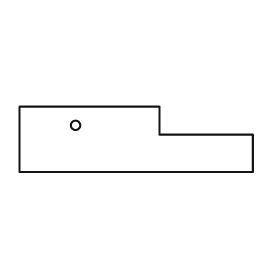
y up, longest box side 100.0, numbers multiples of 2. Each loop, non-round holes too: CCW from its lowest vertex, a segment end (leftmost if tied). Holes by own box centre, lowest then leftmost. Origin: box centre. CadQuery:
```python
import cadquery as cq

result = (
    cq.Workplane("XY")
    .moveTo(-50.0, -14.0)
    .lineTo(50.0, -14.0)
    .lineTo(50.0, 2.0)
    .lineTo(10.0, 2.0)
    .lineTo(10.0, 14.0)
    .lineTo(-50.0, 14.0)
    .close()
    .moveTo(-26.0, 6.0)
    .circle(2.0)
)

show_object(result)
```